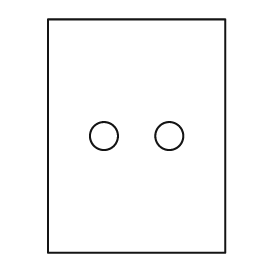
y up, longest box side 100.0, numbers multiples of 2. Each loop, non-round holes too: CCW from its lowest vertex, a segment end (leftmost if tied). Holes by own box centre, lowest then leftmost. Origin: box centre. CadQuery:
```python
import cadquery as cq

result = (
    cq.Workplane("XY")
    .moveTo(-38.0, -50.0)
    .lineTo(38.0, -50.0)
    .lineTo(38.0, 50.0)
    .lineTo(-38.0, 50.0)
    .close()
    .moveTo(-14.0, 0.0)
    .circle(6.0)
    .moveTo(14.0, 0.0)
    .circle(6.0)
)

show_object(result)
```